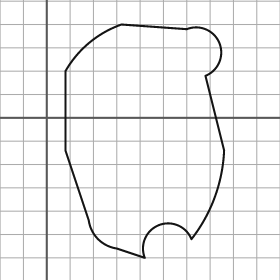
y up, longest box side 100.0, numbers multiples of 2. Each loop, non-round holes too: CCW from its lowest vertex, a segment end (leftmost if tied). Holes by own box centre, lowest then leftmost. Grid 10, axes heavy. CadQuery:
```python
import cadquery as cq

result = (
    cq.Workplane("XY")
    .moveTo(42.0, -60.0)
    .threePointArc((48.0, -46.0), (62.0, -52.0))
    .threePointArc((72.0, -34.0), (76.0, -14.0))
    .lineTo(68.0, 18.0)
    .threePointArc((74.0, 32.0), (60.0, 38.0))
    .lineTo(32.0, 40.0)
    .threePointArc((18.0, 32.0), (8.0, 20.0))
    .lineTo(8.0, -14.0)
    .lineTo(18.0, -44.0)
    .threePointArc((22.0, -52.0), (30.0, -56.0))
    .close()
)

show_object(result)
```